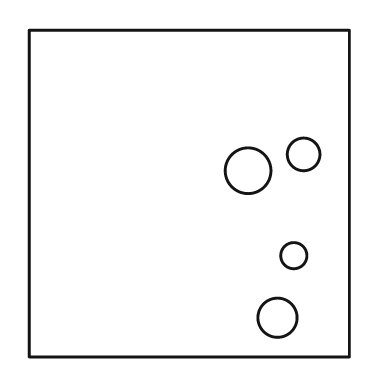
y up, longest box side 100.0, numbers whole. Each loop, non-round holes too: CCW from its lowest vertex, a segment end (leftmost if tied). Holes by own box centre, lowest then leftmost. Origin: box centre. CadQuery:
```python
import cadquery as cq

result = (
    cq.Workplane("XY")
    .moveTo(-49.0, -50.0)
    .lineTo(49.0, -50.0)
    .lineTo(49.0, 50.0)
    .lineTo(-49.0, 50.0)
    .close()
    .moveTo(27.0, -38.0)
    .circle(6.0)
    .moveTo(32.0, -19.0)
    .circle(4.0)
    .moveTo(18.0, 7.0)
    .circle(7.0)
    .moveTo(35.0, 12.0)
    .circle(5.0)
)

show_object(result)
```